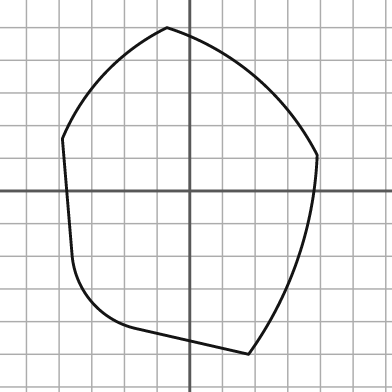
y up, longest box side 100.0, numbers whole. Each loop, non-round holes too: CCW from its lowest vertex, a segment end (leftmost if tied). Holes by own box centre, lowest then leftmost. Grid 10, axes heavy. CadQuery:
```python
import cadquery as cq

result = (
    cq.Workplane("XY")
    .moveTo(18.0, -50.0)
    .threePointArc((33.0, -21.0), (39.0, 11.0))
    .threePointArc((20.0, 35.0), (-7.0, 50.0))
    .threePointArc((-26.0, 36.0), (-39.0, 16.0))
    .lineTo(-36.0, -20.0)
    .threePointArc((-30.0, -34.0), (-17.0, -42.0))
    .close()
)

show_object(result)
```